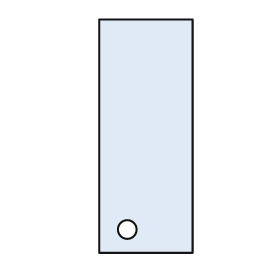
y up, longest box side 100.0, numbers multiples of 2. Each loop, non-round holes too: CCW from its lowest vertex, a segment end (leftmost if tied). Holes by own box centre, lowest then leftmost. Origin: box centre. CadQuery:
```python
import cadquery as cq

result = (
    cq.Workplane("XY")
    .moveTo(-20.0, -50.0)
    .lineTo(20.0, -50.0)
    .lineTo(20.0, 50.0)
    .lineTo(-20.0, 50.0)
    .close()
    .moveTo(-8.0, -40.0)
    .circle(4.0)
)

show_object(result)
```